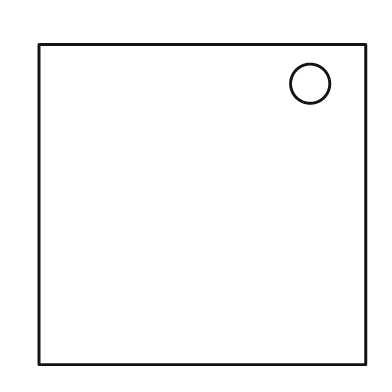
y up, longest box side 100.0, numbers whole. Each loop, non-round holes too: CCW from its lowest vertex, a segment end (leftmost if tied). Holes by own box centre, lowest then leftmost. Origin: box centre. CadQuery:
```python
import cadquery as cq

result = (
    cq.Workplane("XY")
    .moveTo(-50.0, -49.0)
    .lineTo(50.0, -49.0)
    .lineTo(50.0, 49.0)
    .lineTo(-50.0, 49.0)
    .close()
    .moveTo(33.0, 37.0)
    .circle(6.0)
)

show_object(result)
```